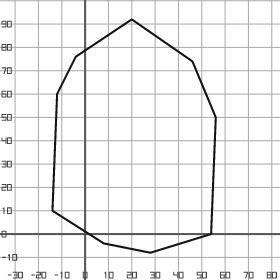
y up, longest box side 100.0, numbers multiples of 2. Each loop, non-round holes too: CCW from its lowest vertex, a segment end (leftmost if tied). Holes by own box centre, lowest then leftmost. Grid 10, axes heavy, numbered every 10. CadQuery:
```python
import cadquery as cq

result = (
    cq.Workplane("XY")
    .moveTo(28.0, -8.0)
    .lineTo(54.0, 0.0)
    .lineTo(56.0, 50.0)
    .lineTo(46.0, 74.0)
    .lineTo(20.0, 92.0)
    .lineTo(-4.0, 76.0)
    .lineTo(-12.0, 60.0)
    .lineTo(-14.0, 10.0)
    .lineTo(8.0, -4.0)
    .close()
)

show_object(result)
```